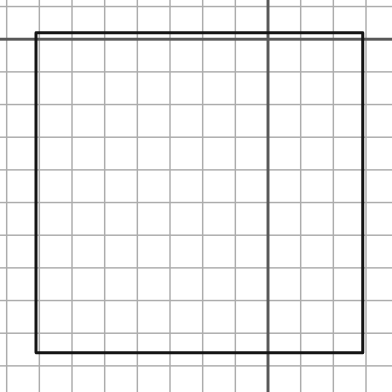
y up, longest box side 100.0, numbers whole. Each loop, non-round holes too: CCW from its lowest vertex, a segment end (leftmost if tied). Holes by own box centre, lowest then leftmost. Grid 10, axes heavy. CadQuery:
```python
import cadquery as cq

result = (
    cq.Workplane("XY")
    .moveTo(-71.0, -96.0)
    .lineTo(29.0, -96.0)
    .lineTo(29.0, 2.0)
    .lineTo(-71.0, 2.0)
    .close()
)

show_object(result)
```